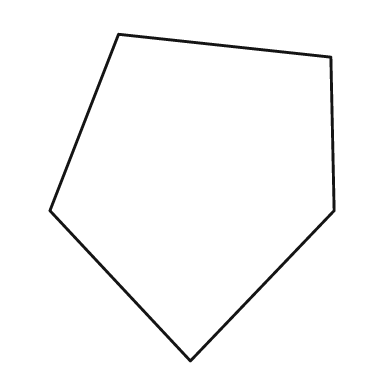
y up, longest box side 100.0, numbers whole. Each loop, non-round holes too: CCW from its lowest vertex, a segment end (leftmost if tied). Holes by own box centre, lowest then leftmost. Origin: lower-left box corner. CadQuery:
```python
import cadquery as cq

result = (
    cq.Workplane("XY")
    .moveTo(43.0, 0.0)
    .lineTo(87.0, 46.0)
    .lineTo(86.0, 93.0)
    .lineTo(21.0, 100.0)
    .lineTo(0.0, 46.0)
    .close()
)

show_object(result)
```